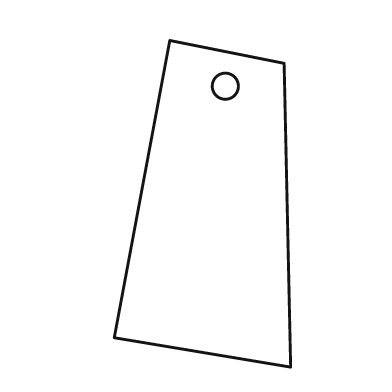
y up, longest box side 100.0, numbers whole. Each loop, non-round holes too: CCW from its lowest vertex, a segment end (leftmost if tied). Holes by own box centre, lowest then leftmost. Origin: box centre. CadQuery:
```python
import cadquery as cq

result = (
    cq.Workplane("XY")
    .moveTo(27.0, -50.0)
    .lineTo(25.0, 43.0)
    .lineTo(-10.0, 50.0)
    .lineTo(-27.0, -41.0)
    .close()
    .moveTo(7.0, 36.0)
    .circle(4.0)
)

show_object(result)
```